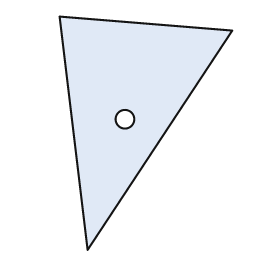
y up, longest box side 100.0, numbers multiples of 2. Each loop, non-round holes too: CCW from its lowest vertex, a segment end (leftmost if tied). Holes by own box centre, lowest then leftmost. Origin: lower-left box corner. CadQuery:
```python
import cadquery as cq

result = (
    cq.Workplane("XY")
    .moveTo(12.0, 0.0)
    .lineTo(74.0, 94.0)
    .lineTo(0.0, 100.0)
    .close()
    .moveTo(28.0, 56.0)
    .circle(4.0)
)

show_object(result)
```